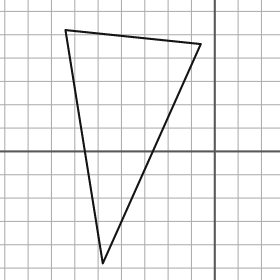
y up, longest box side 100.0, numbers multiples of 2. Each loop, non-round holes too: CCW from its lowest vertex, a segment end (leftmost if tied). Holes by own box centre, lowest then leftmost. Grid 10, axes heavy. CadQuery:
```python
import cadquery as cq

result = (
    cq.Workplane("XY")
    .moveTo(-48.0, -48.0)
    .lineTo(-6.0, 46.0)
    .lineTo(-64.0, 52.0)
    .close()
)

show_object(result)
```